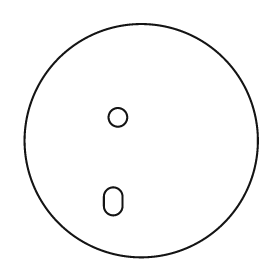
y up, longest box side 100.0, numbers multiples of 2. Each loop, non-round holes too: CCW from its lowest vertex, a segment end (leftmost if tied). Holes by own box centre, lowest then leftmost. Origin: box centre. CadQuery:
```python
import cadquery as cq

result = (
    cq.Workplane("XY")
    .moveTo(0.0, 0.0)
    .circle(50.0)
    .moveTo(-16.0, -28.0)
    .threePointArc((-12.0, -32.0), (-8.0, -28.0))
    .lineTo(-8.0, -24.0)
    .threePointArc((-12.0, -20.0), (-16.0, -24.0))
    .close()
    .moveTo(-10.0, 10.0)
    .circle(4.0)
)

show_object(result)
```